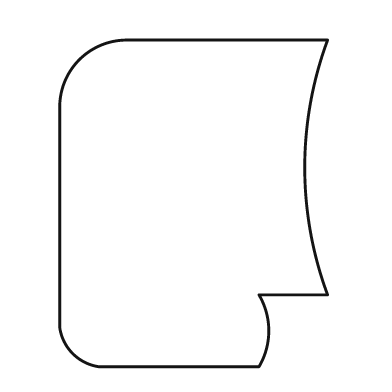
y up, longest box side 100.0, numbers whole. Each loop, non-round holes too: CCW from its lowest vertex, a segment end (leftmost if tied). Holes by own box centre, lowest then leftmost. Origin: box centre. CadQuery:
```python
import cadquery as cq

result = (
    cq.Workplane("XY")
    .moveTo(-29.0, -50.0)
    .lineTo(20.0, -50.0)
    .threePointArc((23.0, -39.0), (20.0, -28.0))
    .lineTo(41.0, -28.0)
    .threePointArc((34.0, 11.0), (41.0, 50.0))
    .lineTo(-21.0, 50.0)
    .threePointArc((-35.0, 44.0), (-41.0, 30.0))
    .lineTo(-41.0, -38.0)
    .threePointArc((-37.0, -46.0), (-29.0, -50.0))
    .close()
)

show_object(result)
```